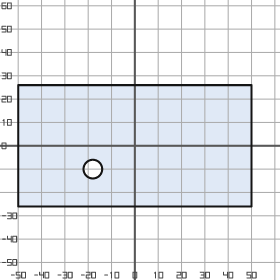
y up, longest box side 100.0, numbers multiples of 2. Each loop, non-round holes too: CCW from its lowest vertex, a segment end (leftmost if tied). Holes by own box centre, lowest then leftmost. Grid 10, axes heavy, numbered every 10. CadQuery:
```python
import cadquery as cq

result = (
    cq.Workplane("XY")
    .moveTo(-50.0, -26.0)
    .lineTo(50.0, -26.0)
    .lineTo(50.0, 26.0)
    .lineTo(-50.0, 26.0)
    .close()
    .moveTo(-18.0, -10.0)
    .circle(4.0)
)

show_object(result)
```